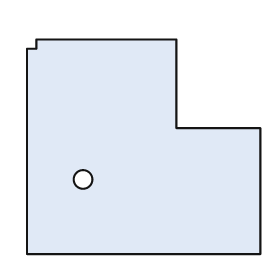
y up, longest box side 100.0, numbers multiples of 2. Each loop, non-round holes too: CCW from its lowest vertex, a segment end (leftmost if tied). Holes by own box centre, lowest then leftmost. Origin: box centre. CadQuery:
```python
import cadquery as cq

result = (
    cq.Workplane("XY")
    .moveTo(-50.0, -46.0)
    .lineTo(50.0, -46.0)
    .lineTo(50.0, 8.0)
    .lineTo(14.0, 8.0)
    .lineTo(14.0, 46.0)
    .lineTo(-46.0, 46.0)
    .lineTo(-46.0, 42.0)
    .lineTo(-50.0, 42.0)
    .close()
    .moveTo(-26.0, -14.0)
    .circle(4.0)
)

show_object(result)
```